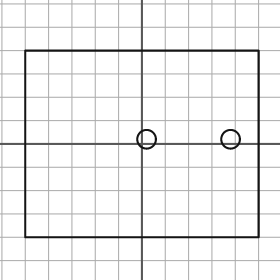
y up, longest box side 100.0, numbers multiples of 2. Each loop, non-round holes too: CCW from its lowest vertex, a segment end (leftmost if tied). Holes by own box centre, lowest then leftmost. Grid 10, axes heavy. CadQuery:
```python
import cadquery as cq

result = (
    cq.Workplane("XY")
    .moveTo(-50.0, -40.0)
    .lineTo(50.0, -40.0)
    .lineTo(50.0, 40.0)
    .lineTo(-50.0, 40.0)
    .close()
    .moveTo(2.0, 2.0)
    .circle(4.0)
    .moveTo(38.0, 2.0)
    .circle(4.0)
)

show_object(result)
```